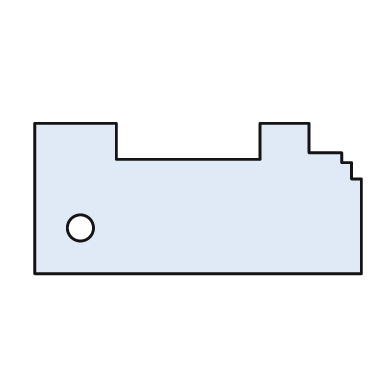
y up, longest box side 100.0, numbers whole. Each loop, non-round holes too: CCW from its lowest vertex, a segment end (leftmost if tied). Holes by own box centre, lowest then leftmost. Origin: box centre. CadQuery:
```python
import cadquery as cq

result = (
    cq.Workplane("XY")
    .moveTo(-50.0, -23.0)
    .lineTo(50.0, -23.0)
    .lineTo(50.0, 6.0)
    .lineTo(47.0, 6.0)
    .lineTo(47.0, 11.0)
    .lineTo(44.0, 11.0)
    .lineTo(44.0, 14.0)
    .lineTo(34.0, 14.0)
    .lineTo(34.0, 23.0)
    .lineTo(19.0, 23.0)
    .lineTo(19.0, 12.0)
    .lineTo(-25.0, 12.0)
    .lineTo(-25.0, 23.0)
    .lineTo(-50.0, 23.0)
    .close()
    .moveTo(-36.0, -9.0)
    .circle(4.0)
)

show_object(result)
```